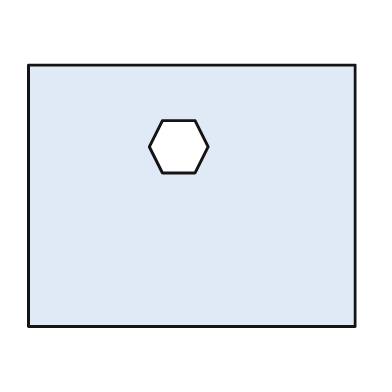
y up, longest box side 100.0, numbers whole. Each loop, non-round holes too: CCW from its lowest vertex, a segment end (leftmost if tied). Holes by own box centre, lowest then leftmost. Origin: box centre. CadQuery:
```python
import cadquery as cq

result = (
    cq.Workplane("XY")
    .moveTo(-50.0, -40.0)
    .lineTo(50.0, -40.0)
    .lineTo(50.0, 40.0)
    .lineTo(-50.0, 40.0)
    .close()
    .moveTo(-9.0, 7.0)
    .lineTo(1.0, 7.0)
    .lineTo(5.0, 15.0)
    .lineTo(1.0, 23.0)
    .lineTo(-9.0, 23.0)
    .lineTo(-13.0, 15.0)
    .close()
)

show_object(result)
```